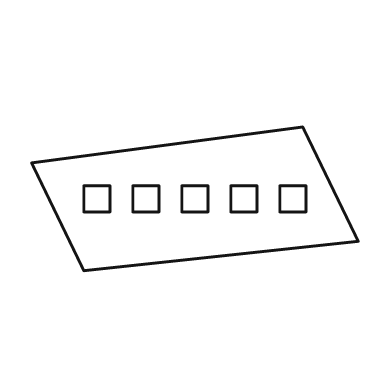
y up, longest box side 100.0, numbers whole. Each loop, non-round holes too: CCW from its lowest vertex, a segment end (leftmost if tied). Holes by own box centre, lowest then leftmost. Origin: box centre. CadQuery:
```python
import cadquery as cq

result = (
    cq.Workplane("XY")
    .moveTo(-34.0, -22.0)
    .lineTo(50.0, -13.0)
    .lineTo(33.0, 22.0)
    .lineTo(-50.0, 11.0)
    .close()
    .moveTo(-34.0, -4.0)
    .lineTo(-26.0, -4.0)
    .lineTo(-26.0, 4.0)
    .lineTo(-34.0, 4.0)
    .close()
    .moveTo(-19.0, -4.0)
    .lineTo(-11.0, -4.0)
    .lineTo(-11.0, 4.0)
    .lineTo(-19.0, 4.0)
    .close()
    .moveTo(-4.0, -4.0)
    .lineTo(4.0, -4.0)
    .lineTo(4.0, 4.0)
    .lineTo(-4.0, 4.0)
    .close()
    .moveTo(11.0, -4.0)
    .lineTo(19.0, -4.0)
    .lineTo(19.0, 4.0)
    .lineTo(11.0, 4.0)
    .close()
    .moveTo(26.0, -4.0)
    .lineTo(34.0, -4.0)
    .lineTo(34.0, 4.0)
    .lineTo(26.0, 4.0)
    .close()
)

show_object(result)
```